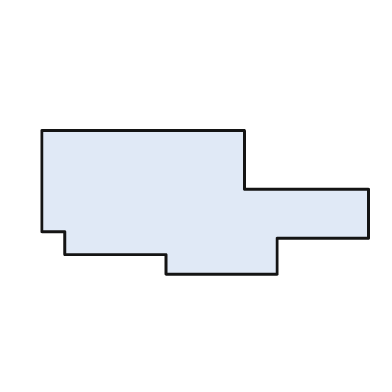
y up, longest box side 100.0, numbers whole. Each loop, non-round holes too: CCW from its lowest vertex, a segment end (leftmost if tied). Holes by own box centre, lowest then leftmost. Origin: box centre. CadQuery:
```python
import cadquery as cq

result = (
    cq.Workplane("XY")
    .moveTo(-12.0, -22.0)
    .lineTo(22.0, -22.0)
    .lineTo(22.0, -11.0)
    .lineTo(50.0, -11.0)
    .lineTo(50.0, 4.0)
    .lineTo(12.0, 4.0)
    .lineTo(12.0, 22.0)
    .lineTo(-50.0, 22.0)
    .lineTo(-50.0, -9.0)
    .lineTo(-43.0, -9.0)
    .lineTo(-43.0, -16.0)
    .lineTo(-12.0, -16.0)
    .close()
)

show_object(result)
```